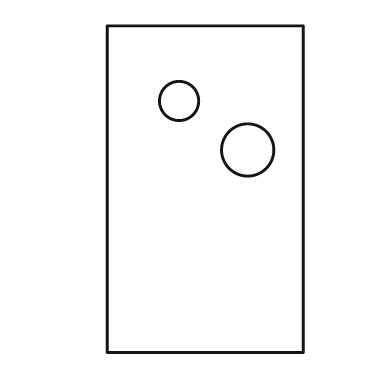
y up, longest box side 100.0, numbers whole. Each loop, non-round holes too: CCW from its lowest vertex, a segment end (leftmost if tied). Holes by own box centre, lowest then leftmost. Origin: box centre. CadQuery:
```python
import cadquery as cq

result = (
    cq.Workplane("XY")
    .moveTo(-30.0, -50.0)
    .lineTo(30.0, -50.0)
    .lineTo(30.0, 50.0)
    .lineTo(-30.0, 50.0)
    .close()
    .moveTo(13.0, 12.0)
    .circle(8.0)
    .moveTo(-8.0, 27.0)
    .circle(6.0)
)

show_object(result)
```